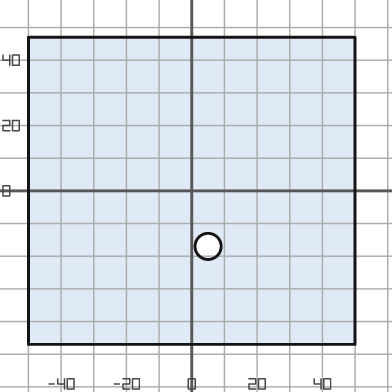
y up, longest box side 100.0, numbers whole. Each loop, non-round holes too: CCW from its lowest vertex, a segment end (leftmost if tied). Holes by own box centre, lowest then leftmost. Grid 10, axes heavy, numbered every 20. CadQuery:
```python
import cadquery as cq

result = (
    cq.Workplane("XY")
    .moveTo(-50.0, -47.0)
    .lineTo(50.0, -47.0)
    .lineTo(50.0, 47.0)
    .lineTo(-50.0, 47.0)
    .close()
    .moveTo(5.0, -17.0)
    .circle(4.0)
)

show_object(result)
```